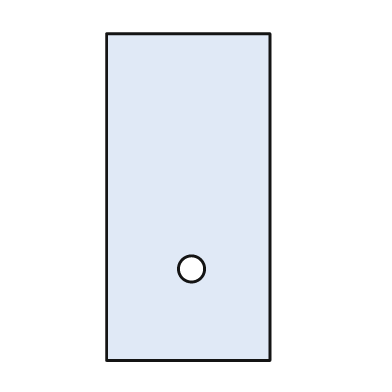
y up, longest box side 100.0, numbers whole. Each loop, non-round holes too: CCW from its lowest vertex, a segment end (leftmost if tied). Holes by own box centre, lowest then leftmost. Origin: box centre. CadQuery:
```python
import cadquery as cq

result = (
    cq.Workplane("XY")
    .moveTo(-25.0, -50.0)
    .lineTo(25.0, -50.0)
    .lineTo(25.0, 50.0)
    .lineTo(-25.0, 50.0)
    .close()
    .moveTo(1.0, -22.0)
    .circle(4.0)
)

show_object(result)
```